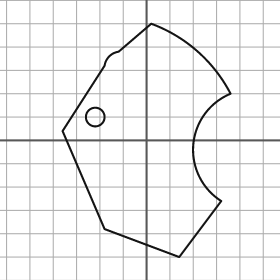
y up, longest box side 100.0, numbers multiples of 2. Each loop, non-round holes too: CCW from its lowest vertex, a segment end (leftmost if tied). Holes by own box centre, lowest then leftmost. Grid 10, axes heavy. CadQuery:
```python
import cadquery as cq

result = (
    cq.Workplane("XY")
    .moveTo(14.0, -50.0)
    .lineTo(32.0, -26.0)
    .threePointArc((20.0, -2.0), (36.0, 20.0))
    .threePointArc((22.0, 38.0), (2.0, 50.0))
    .lineTo(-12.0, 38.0)
    .threePointArc((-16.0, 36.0), (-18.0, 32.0))
    .lineTo(-36.0, 4.0)
    .lineTo(-18.0, -38.0)
    .close()
    .moveTo(-22.0, 10.0)
    .circle(4.0)
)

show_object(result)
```